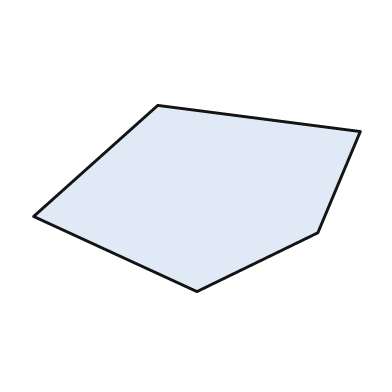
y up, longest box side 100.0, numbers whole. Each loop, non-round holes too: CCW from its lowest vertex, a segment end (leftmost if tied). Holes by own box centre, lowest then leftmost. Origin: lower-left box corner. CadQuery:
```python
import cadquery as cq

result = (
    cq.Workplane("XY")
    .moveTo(50.0, 0.0)
    .lineTo(87.0, 18.0)
    .lineTo(100.0, 49.0)
    .lineTo(38.0, 57.0)
    .lineTo(0.0, 23.0)
    .close()
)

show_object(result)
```